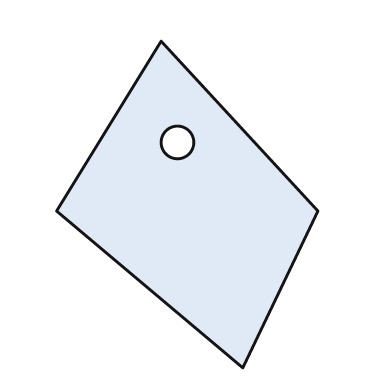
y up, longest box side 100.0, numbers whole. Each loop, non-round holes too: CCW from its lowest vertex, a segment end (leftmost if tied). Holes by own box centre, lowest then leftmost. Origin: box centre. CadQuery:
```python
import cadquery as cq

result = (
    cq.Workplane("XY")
    .moveTo(17.0, -50.0)
    .lineTo(40.0, -2.0)
    .lineTo(-8.0, 50.0)
    .lineTo(-40.0, -2.0)
    .close()
    .moveTo(-3.0, 19.0)
    .circle(5.0)
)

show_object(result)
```